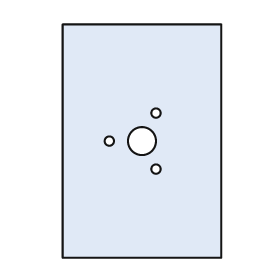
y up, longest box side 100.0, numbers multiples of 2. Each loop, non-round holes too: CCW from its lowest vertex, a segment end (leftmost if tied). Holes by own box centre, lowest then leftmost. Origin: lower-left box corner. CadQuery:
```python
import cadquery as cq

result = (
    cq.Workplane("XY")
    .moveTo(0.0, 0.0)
    .lineTo(68.0, 0.0)
    .lineTo(68.0, 100.0)
    .lineTo(0.0, 100.0)
    .close()
    .moveTo(40.0, 38.0)
    .circle(2.0)
    .moveTo(20.0, 50.0)
    .circle(2.0)
    .moveTo(34.0, 50.0)
    .circle(6.0)
    .moveTo(40.0, 62.0)
    .circle(2.0)
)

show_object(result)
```